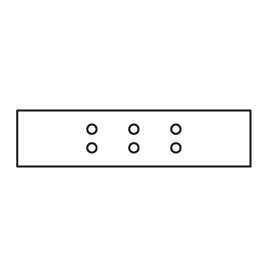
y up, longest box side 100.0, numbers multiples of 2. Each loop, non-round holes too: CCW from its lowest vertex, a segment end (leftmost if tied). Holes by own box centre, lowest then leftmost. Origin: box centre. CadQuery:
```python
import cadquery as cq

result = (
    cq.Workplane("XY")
    .moveTo(-50.0, -12.0)
    .lineTo(50.0, -12.0)
    .lineTo(50.0, 12.0)
    .lineTo(-50.0, 12.0)
    .close()
    .moveTo(-18.0, -4.0)
    .circle(2.0)
    .moveTo(0.0, -4.0)
    .circle(2.0)
    .moveTo(18.0, -4.0)
    .circle(2.0)
    .moveTo(-18.0, 4.0)
    .circle(2.0)
    .moveTo(0.0, 4.0)
    .circle(2.0)
    .moveTo(18.0, 4.0)
    .circle(2.0)
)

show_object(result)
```